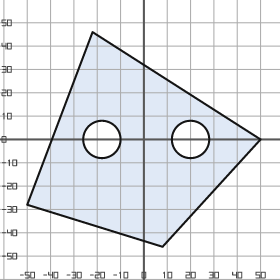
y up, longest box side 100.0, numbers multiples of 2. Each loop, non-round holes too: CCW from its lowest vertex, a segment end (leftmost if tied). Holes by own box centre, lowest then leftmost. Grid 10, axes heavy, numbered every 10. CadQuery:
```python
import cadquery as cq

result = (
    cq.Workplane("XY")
    .moveTo(8.0, -46.0)
    .lineTo(50.0, 0.0)
    .lineTo(-22.0, 46.0)
    .lineTo(-50.0, -28.0)
    .close()
    .moveTo(-18.0, 0.0)
    .circle(8.0)
    .moveTo(20.0, 0.0)
    .circle(8.0)
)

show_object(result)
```